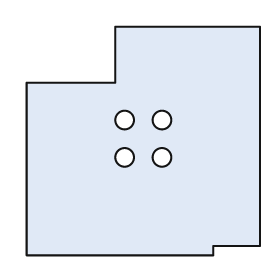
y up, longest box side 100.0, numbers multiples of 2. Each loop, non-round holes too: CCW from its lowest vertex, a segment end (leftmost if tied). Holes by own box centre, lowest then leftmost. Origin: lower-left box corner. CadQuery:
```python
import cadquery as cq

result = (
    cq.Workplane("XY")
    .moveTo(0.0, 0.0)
    .lineTo(80.0, 0.0)
    .lineTo(80.0, 4.0)
    .lineTo(100.0, 4.0)
    .lineTo(100.0, 98.0)
    .lineTo(38.0, 98.0)
    .lineTo(38.0, 74.0)
    .lineTo(0.0, 74.0)
    .close()
    .moveTo(42.0, 42.0)
    .circle(4.0)
    .moveTo(58.0, 42.0)
    .circle(4.0)
    .moveTo(42.0, 58.0)
    .circle(4.0)
    .moveTo(58.0, 58.0)
    .circle(4.0)
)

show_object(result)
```